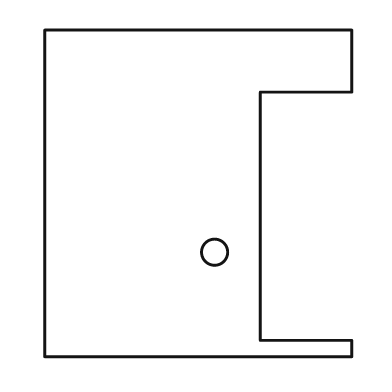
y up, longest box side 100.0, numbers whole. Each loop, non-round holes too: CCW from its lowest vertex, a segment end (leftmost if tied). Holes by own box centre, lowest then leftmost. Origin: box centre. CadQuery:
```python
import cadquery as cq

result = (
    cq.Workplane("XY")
    .moveTo(-47.0, -50.0)
    .lineTo(47.0, -50.0)
    .lineTo(47.0, -45.0)
    .lineTo(19.0, -45.0)
    .lineTo(19.0, 31.0)
    .lineTo(47.0, 31.0)
    .lineTo(47.0, 50.0)
    .lineTo(-47.0, 50.0)
    .close()
    .moveTo(5.0, -18.0)
    .circle(4.0)
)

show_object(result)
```